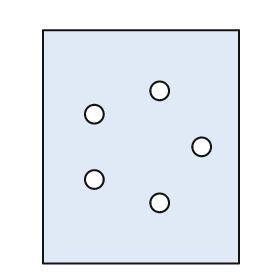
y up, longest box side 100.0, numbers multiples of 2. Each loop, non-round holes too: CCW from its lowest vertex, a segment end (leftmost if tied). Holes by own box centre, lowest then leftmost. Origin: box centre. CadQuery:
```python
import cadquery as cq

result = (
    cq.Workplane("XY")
    .moveTo(-42.0, -50.0)
    .lineTo(42.0, -50.0)
    .lineTo(42.0, 50.0)
    .lineTo(-42.0, 50.0)
    .close()
    .moveTo(8.0, -24.0)
    .circle(4.0)
    .moveTo(-20.0, -14.0)
    .circle(4.0)
    .moveTo(26.0, 0.0)
    .circle(4.0)
    .moveTo(-20.0, 14.0)
    .circle(4.0)
    .moveTo(8.0, 24.0)
    .circle(4.0)
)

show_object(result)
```